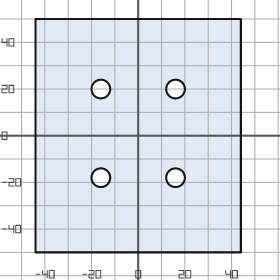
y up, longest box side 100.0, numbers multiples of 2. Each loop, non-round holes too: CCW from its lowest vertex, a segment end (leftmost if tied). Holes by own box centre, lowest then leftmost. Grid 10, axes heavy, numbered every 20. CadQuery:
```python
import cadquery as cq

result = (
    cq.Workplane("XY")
    .moveTo(-44.0, -50.0)
    .lineTo(44.0, -50.0)
    .lineTo(44.0, 50.0)
    .lineTo(-44.0, 50.0)
    .close()
    .moveTo(-16.0, -18.0)
    .circle(4.0)
    .moveTo(16.0, -18.0)
    .circle(4.0)
    .moveTo(-16.0, 20.0)
    .circle(4.0)
    .moveTo(16.0, 20.0)
    .circle(4.0)
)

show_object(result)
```